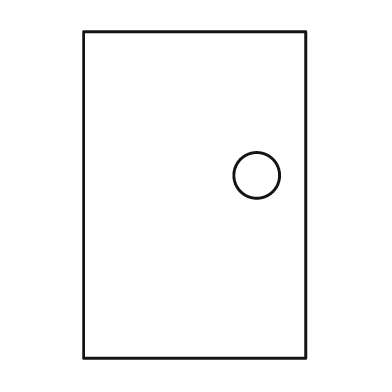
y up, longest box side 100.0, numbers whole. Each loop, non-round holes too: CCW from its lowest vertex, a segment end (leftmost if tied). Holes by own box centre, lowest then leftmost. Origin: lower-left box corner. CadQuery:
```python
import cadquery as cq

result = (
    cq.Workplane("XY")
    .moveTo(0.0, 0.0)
    .lineTo(68.0, 0.0)
    .lineTo(68.0, 100.0)
    .lineTo(0.0, 100.0)
    .close()
    .moveTo(53.0, 56.0)
    .circle(7.0)
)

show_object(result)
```